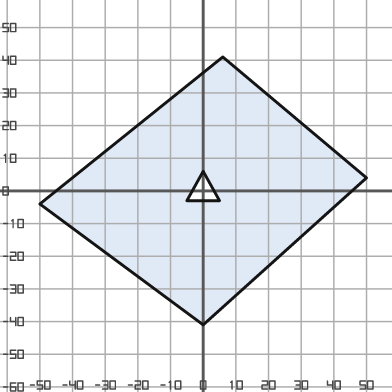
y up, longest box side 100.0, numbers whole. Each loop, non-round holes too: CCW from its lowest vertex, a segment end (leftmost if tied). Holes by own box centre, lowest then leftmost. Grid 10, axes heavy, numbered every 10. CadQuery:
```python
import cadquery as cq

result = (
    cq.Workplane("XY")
    .moveTo(0.0, -41.0)
    .lineTo(50.0, 4.0)
    .lineTo(6.0, 41.0)
    .lineTo(-50.0, -4.0)
    .close()
    .moveTo(-5.0, -3.0)
    .lineTo(5.0, -3.0)
    .lineTo(0.0, 6.0)
    .close()
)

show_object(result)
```